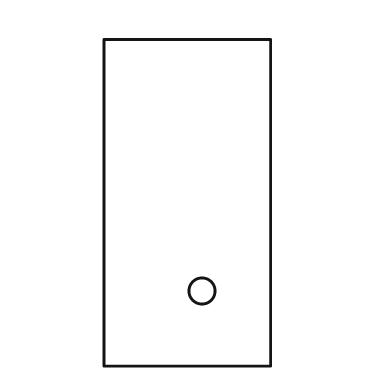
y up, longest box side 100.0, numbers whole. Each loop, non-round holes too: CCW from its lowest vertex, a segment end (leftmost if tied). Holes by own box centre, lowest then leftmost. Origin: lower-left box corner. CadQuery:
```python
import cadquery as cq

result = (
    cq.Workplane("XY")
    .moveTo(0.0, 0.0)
    .lineTo(51.0, 0.0)
    .lineTo(51.0, 100.0)
    .lineTo(0.0, 100.0)
    .close()
    .moveTo(30.0, 23.0)
    .circle(4.0)
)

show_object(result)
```